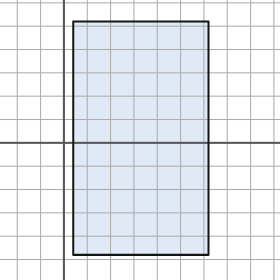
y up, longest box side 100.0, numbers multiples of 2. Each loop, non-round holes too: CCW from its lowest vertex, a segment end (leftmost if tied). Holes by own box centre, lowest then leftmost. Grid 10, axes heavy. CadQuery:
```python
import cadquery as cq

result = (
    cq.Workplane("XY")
    .moveTo(4.0, -48.0)
    .lineTo(62.0, -48.0)
    .lineTo(62.0, 52.0)
    .lineTo(4.0, 52.0)
    .close()
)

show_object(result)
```